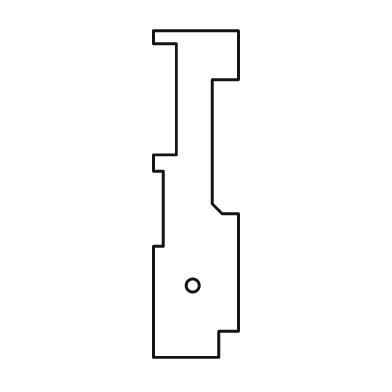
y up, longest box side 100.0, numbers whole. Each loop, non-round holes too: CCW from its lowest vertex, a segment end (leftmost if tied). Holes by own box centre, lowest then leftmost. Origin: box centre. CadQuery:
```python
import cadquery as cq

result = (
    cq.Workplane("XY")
    .moveTo(-13.0, -50.0)
    .lineTo(7.0, -50.0)
    .lineTo(7.0, -42.0)
    .lineTo(13.0, -42.0)
    .lineTo(13.0, -6.0)
    .lineTo(8.0, -6.0)
    .lineTo(5.0, -3.0)
    .lineTo(5.0, 35.0)
    .lineTo(13.0, 35.0)
    .lineTo(13.0, 50.0)
    .lineTo(-13.0, 50.0)
    .lineTo(-13.0, 46.0)
    .lineTo(-6.0, 46.0)
    .lineTo(-6.0, 12.0)
    .lineTo(-13.0, 12.0)
    .lineTo(-13.0, 7.0)
    .lineTo(-10.0, 7.0)
    .lineTo(-10.0, -16.0)
    .lineTo(-13.0, -16.0)
    .close()
    .moveTo(-1.0, -28.0)
    .circle(2.0)
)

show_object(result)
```